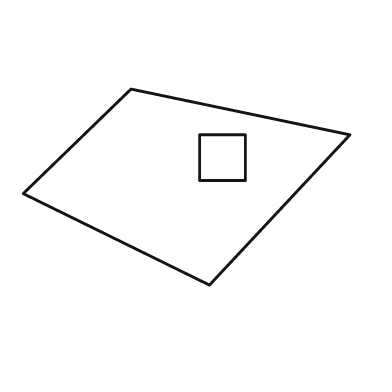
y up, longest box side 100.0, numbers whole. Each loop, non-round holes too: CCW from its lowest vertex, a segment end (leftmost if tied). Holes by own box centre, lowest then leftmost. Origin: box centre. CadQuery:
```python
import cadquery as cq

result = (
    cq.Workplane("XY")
    .moveTo(7.0, -30.0)
    .lineTo(50.0, 16.0)
    .lineTo(-17.0, 30.0)
    .lineTo(-50.0, -2.0)
    .close()
    .moveTo(4.0, 2.0)
    .lineTo(18.0, 2.0)
    .lineTo(18.0, 16.0)
    .lineTo(4.0, 16.0)
    .close()
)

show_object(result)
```